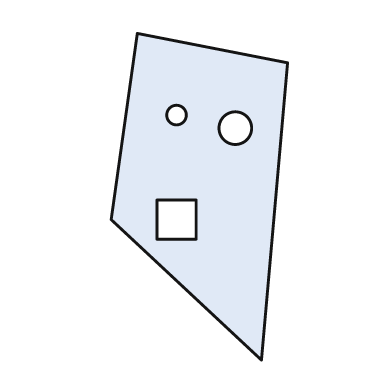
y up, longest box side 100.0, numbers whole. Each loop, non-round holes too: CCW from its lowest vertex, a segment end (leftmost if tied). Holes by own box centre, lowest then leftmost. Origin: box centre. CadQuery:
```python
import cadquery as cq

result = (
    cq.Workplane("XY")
    .moveTo(19.0, -50.0)
    .lineTo(27.0, 41.0)
    .lineTo(-19.0, 50.0)
    .lineTo(-27.0, -7.0)
    .close()
    .moveTo(-13.0, -13.0)
    .lineTo(-1.0, -13.0)
    .lineTo(-1.0, -1.0)
    .lineTo(-13.0, -1.0)
    .close()
    .moveTo(11.0, 21.0)
    .circle(5.0)
    .moveTo(-7.0, 25.0)
    .circle(3.0)
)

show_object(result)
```